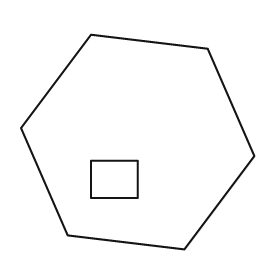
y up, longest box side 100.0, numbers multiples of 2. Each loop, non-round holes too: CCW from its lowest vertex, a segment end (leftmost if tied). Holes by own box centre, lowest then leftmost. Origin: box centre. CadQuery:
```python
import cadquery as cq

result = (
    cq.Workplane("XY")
    .moveTo(20.0, -46.0)
    .lineTo(50.0, -6.0)
    .lineTo(30.0, 40.0)
    .lineTo(-20.0, 46.0)
    .lineTo(-50.0, 6.0)
    .lineTo(-30.0, -40.0)
    .close()
    .moveTo(-20.0, -24.0)
    .lineTo(0.0, -24.0)
    .lineTo(0.0, -8.0)
    .lineTo(-20.0, -8.0)
    .close()
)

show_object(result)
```